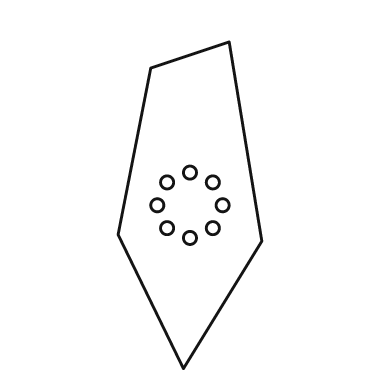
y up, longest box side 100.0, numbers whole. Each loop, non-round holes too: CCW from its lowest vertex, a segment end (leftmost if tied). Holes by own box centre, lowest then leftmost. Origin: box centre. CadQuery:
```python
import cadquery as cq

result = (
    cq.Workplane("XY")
    .moveTo(-2.0, -50.0)
    .lineTo(22.0, -11.0)
    .lineTo(12.0, 50.0)
    .lineTo(-12.0, 42.0)
    .lineTo(-22.0, -9.0)
    .close()
    .moveTo(0.0, -10.0)
    .circle(2.0)
    .moveTo(-7.0, -7.0)
    .circle(2.0)
    .moveTo(7.0, -7.0)
    .circle(2.0)
    .moveTo(-10.0, 0.0)
    .circle(2.0)
    .moveTo(10.0, 0.0)
    .circle(2.0)
    .moveTo(-7.0, 7.0)
    .circle(2.0)
    .moveTo(7.0, 7.0)
    .circle(2.0)
    .moveTo(0.0, 10.0)
    .circle(2.0)
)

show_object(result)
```